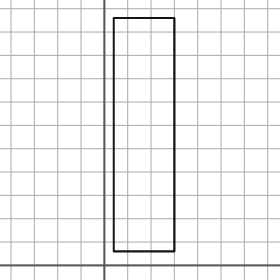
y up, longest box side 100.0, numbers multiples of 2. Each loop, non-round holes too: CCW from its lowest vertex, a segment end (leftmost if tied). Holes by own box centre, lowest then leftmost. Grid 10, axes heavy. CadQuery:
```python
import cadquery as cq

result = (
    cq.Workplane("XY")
    .moveTo(4.0, 6.0)
    .lineTo(30.0, 6.0)
    .lineTo(30.0, 106.0)
    .lineTo(4.0, 106.0)
    .close()
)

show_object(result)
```